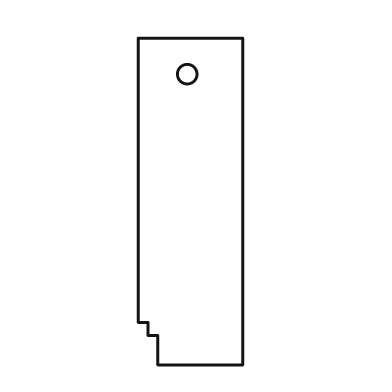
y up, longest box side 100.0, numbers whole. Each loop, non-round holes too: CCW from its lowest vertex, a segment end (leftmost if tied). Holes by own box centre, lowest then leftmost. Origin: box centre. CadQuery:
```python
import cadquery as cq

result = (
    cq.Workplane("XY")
    .moveTo(-10.0, -50.0)
    .lineTo(16.0, -50.0)
    .lineTo(16.0, 50.0)
    .lineTo(-16.0, 50.0)
    .lineTo(-16.0, -37.0)
    .lineTo(-13.0, -37.0)
    .lineTo(-13.0, -41.0)
    .lineTo(-10.0, -41.0)
    .close()
    .moveTo(-1.0, 39.0)
    .circle(3.0)
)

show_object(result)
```